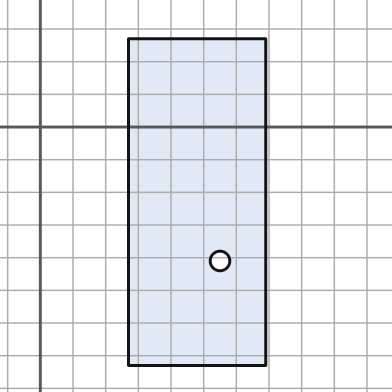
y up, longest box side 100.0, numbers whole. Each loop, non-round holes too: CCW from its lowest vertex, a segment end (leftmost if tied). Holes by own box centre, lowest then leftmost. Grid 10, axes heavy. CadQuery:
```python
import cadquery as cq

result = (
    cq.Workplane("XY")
    .moveTo(27.0, -73.0)
    .lineTo(69.0, -73.0)
    .lineTo(69.0, 27.0)
    .lineTo(27.0, 27.0)
    .close()
    .moveTo(55.0, -41.0)
    .circle(3.0)
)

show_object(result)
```